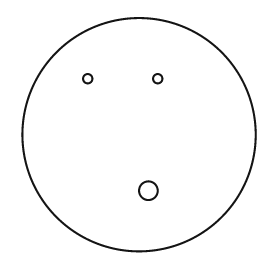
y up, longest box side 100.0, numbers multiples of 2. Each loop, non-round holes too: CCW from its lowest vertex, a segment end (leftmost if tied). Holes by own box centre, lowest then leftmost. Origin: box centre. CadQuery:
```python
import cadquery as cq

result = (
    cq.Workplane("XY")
    .moveTo(0.0, 0.0)
    .circle(50.0)
    .moveTo(4.0, -24.0)
    .circle(4.0)
    .moveTo(-22.0, 24.0)
    .circle(2.0)
    .moveTo(8.0, 24.0)
    .circle(2.0)
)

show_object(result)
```